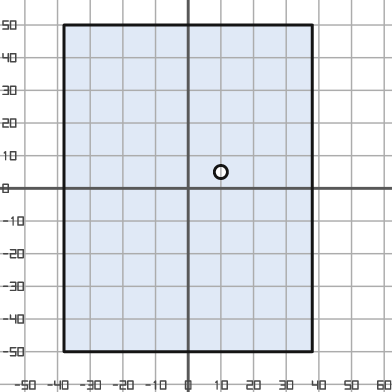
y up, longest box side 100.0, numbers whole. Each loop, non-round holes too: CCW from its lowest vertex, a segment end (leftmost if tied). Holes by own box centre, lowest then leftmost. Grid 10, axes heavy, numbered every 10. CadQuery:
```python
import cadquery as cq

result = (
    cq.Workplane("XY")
    .moveTo(-38.0, -50.0)
    .lineTo(38.0, -50.0)
    .lineTo(38.0, 50.0)
    .lineTo(-38.0, 50.0)
    .close()
    .moveTo(10.0, 5.0)
    .circle(2.0)
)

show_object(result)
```